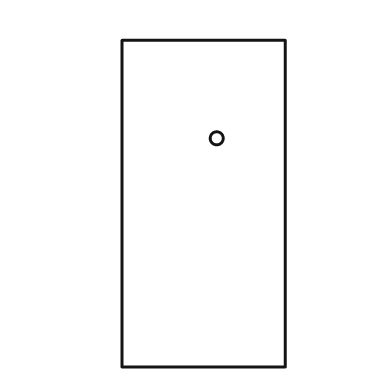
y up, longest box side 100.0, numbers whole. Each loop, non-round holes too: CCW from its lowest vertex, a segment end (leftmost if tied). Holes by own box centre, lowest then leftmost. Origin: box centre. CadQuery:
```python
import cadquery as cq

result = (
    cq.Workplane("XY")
    .moveTo(-25.0, -50.0)
    .lineTo(25.0, -50.0)
    .lineTo(25.0, 50.0)
    .lineTo(-25.0, 50.0)
    .close()
    .moveTo(4.0, 20.0)
    .circle(2.0)
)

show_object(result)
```